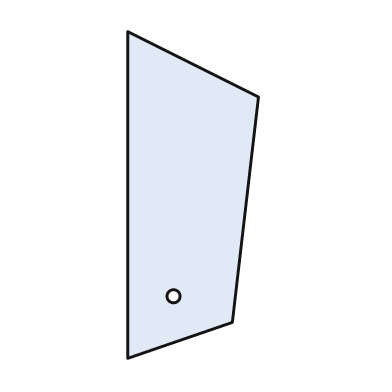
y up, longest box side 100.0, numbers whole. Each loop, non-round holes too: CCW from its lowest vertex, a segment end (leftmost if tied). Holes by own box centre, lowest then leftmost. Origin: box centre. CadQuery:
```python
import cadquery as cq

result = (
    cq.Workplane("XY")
    .moveTo(-20.0, -50.0)
    .lineTo(12.0, -39.0)
    .lineTo(20.0, 30.0)
    .lineTo(-20.0, 50.0)
    .close()
    .moveTo(-6.0, -31.0)
    .circle(2.0)
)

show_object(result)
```